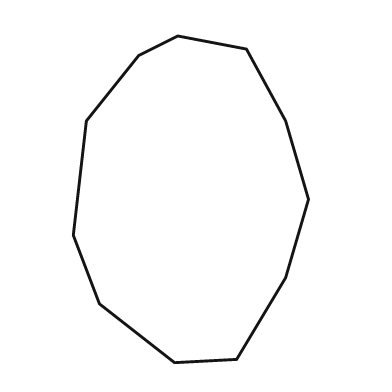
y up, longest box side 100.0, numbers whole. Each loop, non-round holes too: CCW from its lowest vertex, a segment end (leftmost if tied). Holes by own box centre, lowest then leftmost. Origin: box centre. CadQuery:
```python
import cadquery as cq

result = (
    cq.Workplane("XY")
    .moveTo(-5.0, -50.0)
    .lineTo(14.0, -49.0)
    .lineTo(29.0, -24.0)
    .lineTo(36.0, 0.0)
    .lineTo(29.0, 24.0)
    .lineTo(17.0, 46.0)
    .lineTo(-4.0, 50.0)
    .lineTo(-16.0, 44.0)
    .lineTo(-32.0, 24.0)
    .lineTo(-36.0, -11.0)
    .lineTo(-28.0, -32.0)
    .close()
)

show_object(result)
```